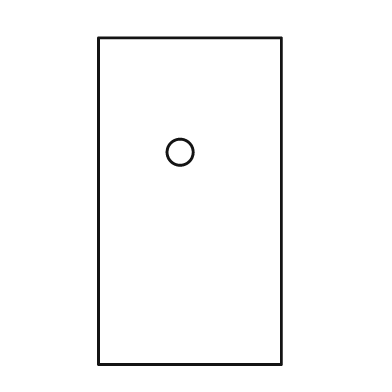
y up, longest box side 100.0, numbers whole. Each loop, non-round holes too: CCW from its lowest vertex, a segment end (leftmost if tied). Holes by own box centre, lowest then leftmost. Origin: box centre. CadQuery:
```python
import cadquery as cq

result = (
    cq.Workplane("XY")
    .moveTo(-28.0, -50.0)
    .lineTo(28.0, -50.0)
    .lineTo(28.0, 50.0)
    .lineTo(-28.0, 50.0)
    .close()
    .moveTo(-3.0, 15.0)
    .circle(4.0)
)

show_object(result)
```